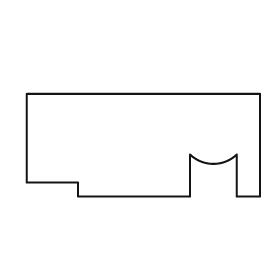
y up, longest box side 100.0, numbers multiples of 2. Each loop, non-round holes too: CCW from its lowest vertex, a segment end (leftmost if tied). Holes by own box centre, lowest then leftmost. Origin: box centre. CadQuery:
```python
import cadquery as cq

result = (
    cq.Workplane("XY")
    .moveTo(-28.0, -22.0)
    .lineTo(20.0, -22.0)
    .lineTo(20.0, -4.0)
    .threePointArc((30.0, -8.0), (40.0, -4.0))
    .lineTo(40.0, -22.0)
    .lineTo(50.0, -22.0)
    .lineTo(50.0, 22.0)
    .lineTo(-50.0, 22.0)
    .lineTo(-50.0, -16.0)
    .lineTo(-28.0, -16.0)
    .close()
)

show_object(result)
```